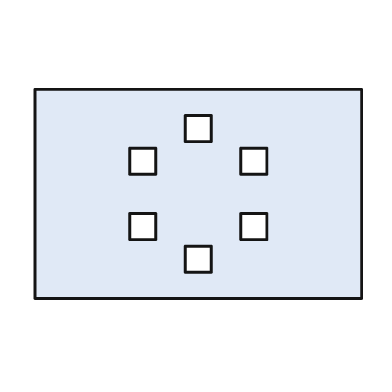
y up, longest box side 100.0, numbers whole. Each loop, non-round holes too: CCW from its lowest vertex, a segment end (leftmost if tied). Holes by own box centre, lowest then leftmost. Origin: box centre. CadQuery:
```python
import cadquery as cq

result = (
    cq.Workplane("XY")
    .moveTo(-50.0, -32.0)
    .lineTo(50.0, -32.0)
    .lineTo(50.0, 32.0)
    .lineTo(-50.0, 32.0)
    .close()
    .moveTo(-4.0, -24.0)
    .lineTo(4.0, -24.0)
    .lineTo(4.0, -16.0)
    .lineTo(-4.0, -16.0)
    .close()
    .moveTo(-21.0, -14.0)
    .lineTo(-13.0, -14.0)
    .lineTo(-13.0, -6.0)
    .lineTo(-21.0, -6.0)
    .close()
    .moveTo(13.0, -14.0)
    .lineTo(21.0, -14.0)
    .lineTo(21.0, -6.0)
    .lineTo(13.0, -6.0)
    .close()
    .moveTo(-21.0, 6.0)
    .lineTo(-13.0, 6.0)
    .lineTo(-13.0, 14.0)
    .lineTo(-21.0, 14.0)
    .close()
    .moveTo(13.0, 6.0)
    .lineTo(21.0, 6.0)
    .lineTo(21.0, 14.0)
    .lineTo(13.0, 14.0)
    .close()
    .moveTo(-4.0, 16.0)
    .lineTo(4.0, 16.0)
    .lineTo(4.0, 24.0)
    .lineTo(-4.0, 24.0)
    .close()
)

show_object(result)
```